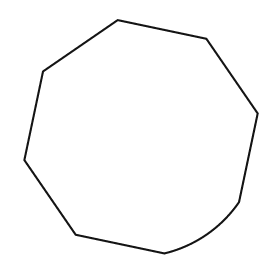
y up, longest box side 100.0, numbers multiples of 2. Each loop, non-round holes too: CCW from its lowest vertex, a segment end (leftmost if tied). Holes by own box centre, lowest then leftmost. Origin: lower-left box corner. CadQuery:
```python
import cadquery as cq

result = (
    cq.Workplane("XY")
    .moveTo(60.0, 0.0)
    .threePointArc((78.0, 8.0), (92.0, 22.0))
    .lineTo(100.0, 60.0)
    .lineTo(78.0, 92.0)
    .lineTo(40.0, 100.0)
    .lineTo(8.0, 78.0)
    .lineTo(0.0, 40.0)
    .lineTo(22.0, 8.0)
    .close()
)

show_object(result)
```